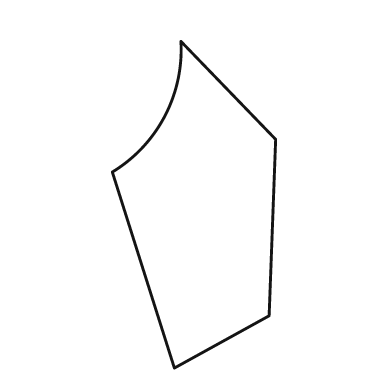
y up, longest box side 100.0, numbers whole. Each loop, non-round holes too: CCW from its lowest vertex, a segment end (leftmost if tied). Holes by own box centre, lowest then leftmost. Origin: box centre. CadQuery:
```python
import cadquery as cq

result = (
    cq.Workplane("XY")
    .moveTo(-6.0, -50.0)
    .lineTo(23.0, -34.0)
    .lineTo(25.0, 20.0)
    .lineTo(-4.0, 50.0)
    .threePointArc((-9.0, 27.0), (-25.0, 10.0))
    .close()
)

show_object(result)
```